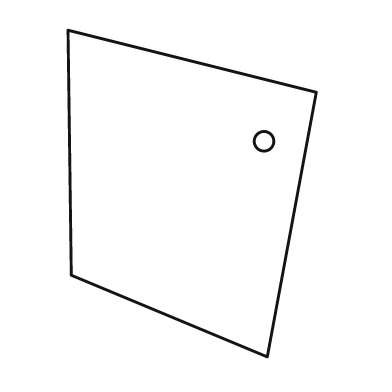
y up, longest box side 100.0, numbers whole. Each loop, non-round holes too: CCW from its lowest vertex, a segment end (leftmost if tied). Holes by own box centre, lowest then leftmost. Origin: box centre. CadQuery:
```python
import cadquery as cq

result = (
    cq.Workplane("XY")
    .moveTo(23.0, -50.0)
    .lineTo(38.0, 31.0)
    .lineTo(-38.0, 50.0)
    .lineTo(-37.0, -25.0)
    .close()
    .moveTo(22.0, 16.0)
    .circle(3.0)
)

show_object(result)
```